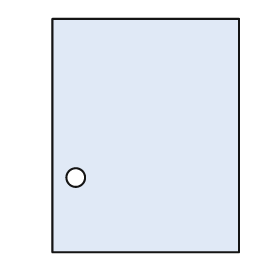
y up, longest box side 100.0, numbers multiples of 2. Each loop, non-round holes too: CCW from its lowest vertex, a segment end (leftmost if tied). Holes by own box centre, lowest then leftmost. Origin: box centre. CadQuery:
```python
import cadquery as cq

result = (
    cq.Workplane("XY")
    .moveTo(-40.0, -50.0)
    .lineTo(40.0, -50.0)
    .lineTo(40.0, 50.0)
    .lineTo(-40.0, 50.0)
    .close()
    .moveTo(-30.0, -18.0)
    .circle(4.0)
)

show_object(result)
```